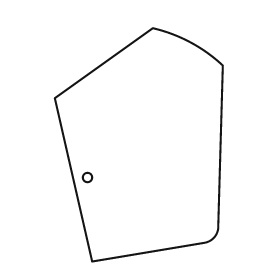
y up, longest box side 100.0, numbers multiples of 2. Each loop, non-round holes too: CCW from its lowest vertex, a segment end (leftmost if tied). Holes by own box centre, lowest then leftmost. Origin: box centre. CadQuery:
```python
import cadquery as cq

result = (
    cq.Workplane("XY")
    .moveTo(-20.0, -50.0)
    .lineTo(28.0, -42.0)
    .threePointArc((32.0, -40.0), (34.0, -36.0))
    .lineTo(36.0, 34.0)
    .threePointArc((22.0, 44.0), (6.0, 50.0))
    .lineTo(-36.0, 20.0)
    .close()
    .moveTo(-22.0, -14.0)
    .circle(2.0)
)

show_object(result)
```